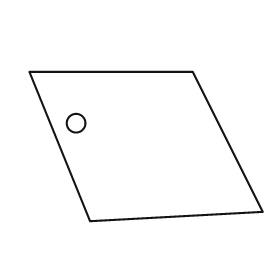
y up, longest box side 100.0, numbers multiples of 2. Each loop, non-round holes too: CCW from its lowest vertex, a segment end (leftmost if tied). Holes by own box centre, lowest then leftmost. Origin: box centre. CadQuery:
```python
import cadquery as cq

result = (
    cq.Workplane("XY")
    .moveTo(-24.0, -32.0)
    .lineTo(50.0, -28.0)
    .lineTo(20.0, 32.0)
    .lineTo(-50.0, 32.0)
    .close()
    .moveTo(-30.0, 10.0)
    .circle(4.0)
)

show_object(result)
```